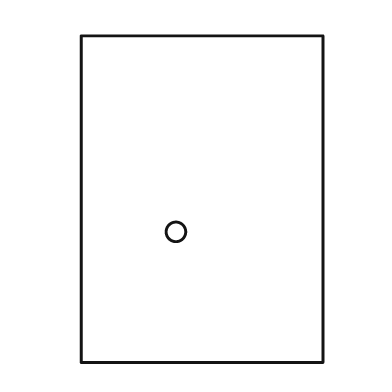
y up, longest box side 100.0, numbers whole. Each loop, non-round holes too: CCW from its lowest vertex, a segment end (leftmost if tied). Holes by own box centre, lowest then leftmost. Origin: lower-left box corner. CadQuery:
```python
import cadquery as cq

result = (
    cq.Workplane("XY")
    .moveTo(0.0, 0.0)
    .lineTo(74.0, 0.0)
    .lineTo(74.0, 100.0)
    .lineTo(0.0, 100.0)
    .close()
    .moveTo(29.0, 40.0)
    .circle(3.0)
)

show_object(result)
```